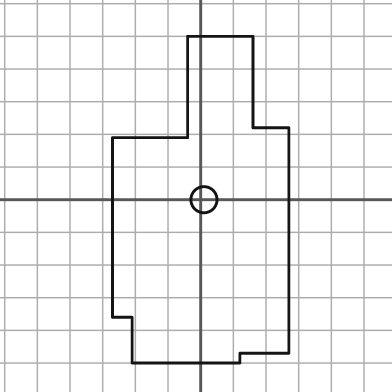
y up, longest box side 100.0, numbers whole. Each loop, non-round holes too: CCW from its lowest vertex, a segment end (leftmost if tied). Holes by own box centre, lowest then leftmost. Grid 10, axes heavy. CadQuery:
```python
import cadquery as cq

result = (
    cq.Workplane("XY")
    .moveTo(-21.0, -50.0)
    .lineTo(12.0, -50.0)
    .lineTo(12.0, -47.0)
    .lineTo(27.0, -47.0)
    .lineTo(27.0, 22.0)
    .lineTo(16.0, 22.0)
    .lineTo(16.0, 50.0)
    .lineTo(-4.0, 50.0)
    .lineTo(-4.0, 19.0)
    .lineTo(-27.0, 19.0)
    .lineTo(-27.0, -36.0)
    .lineTo(-21.0, -36.0)
    .close()
    .moveTo(1.0, 0.0)
    .circle(4.0)
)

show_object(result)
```